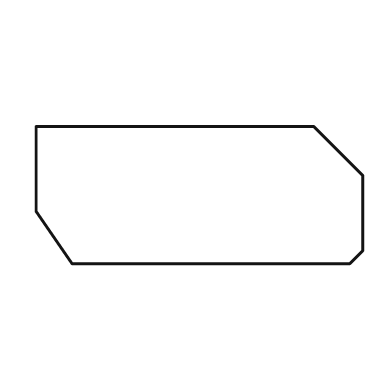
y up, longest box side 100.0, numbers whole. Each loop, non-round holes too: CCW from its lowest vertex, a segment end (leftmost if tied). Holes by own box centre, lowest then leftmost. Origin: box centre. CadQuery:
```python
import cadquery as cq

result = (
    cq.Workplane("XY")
    .moveTo(-39.0, -21.0)
    .lineTo(46.0, -21.0)
    .lineTo(50.0, -17.0)
    .lineTo(50.0, 6.0)
    .lineTo(35.0, 21.0)
    .lineTo(-50.0, 21.0)
    .lineTo(-50.0, -5.0)
    .close()
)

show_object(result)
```